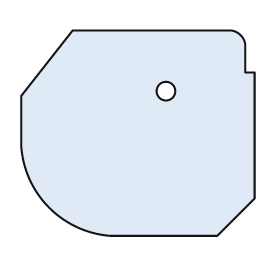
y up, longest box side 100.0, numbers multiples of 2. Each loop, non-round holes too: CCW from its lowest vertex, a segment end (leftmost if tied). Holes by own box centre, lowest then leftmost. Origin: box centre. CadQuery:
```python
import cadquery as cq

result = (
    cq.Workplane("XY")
    .moveTo(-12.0, -44.0)
    .lineTo(34.0, -44.0)
    .lineTo(50.0, -28.0)
    .lineTo(50.0, 26.0)
    .lineTo(46.0, 26.0)
    .lineTo(46.0, 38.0)
    .threePointArc((44.0, 42.0), (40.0, 44.0))
    .lineTo(-28.0, 44.0)
    .lineTo(-50.0, 16.0)
    .lineTo(-50.0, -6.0)
    .threePointArc((-38.0, -32.0), (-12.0, -44.0))
    .close()
    .moveTo(12.0, 18.0)
    .circle(4.0)
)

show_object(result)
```